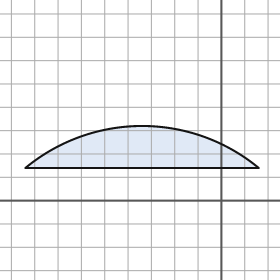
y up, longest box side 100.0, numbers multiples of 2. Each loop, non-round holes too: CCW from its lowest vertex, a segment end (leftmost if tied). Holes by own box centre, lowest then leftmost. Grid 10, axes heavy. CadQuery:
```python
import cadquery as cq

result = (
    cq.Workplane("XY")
    .moveTo(-84.0, 14.0)
    .lineTo(16.0, 14.0)
    .threePointArc((-34.0, 32.0), (-84.0, 14.0))
    .close()
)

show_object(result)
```